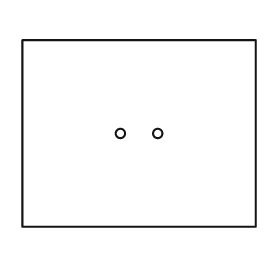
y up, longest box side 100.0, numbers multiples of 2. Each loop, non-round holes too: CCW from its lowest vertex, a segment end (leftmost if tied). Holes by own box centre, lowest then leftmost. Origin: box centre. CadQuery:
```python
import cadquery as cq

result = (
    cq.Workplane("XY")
    .moveTo(-50.0, -40.0)
    .lineTo(50.0, -40.0)
    .lineTo(50.0, 40.0)
    .lineTo(-50.0, 40.0)
    .close()
    .moveTo(-8.0, 0.0)
    .circle(2.0)
    .moveTo(8.0, 0.0)
    .circle(2.0)
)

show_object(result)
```